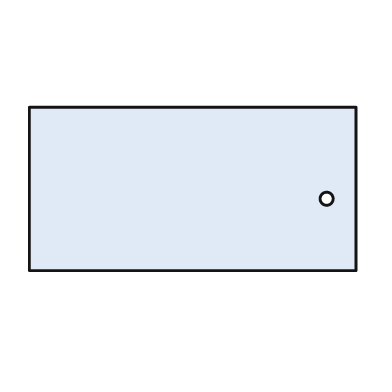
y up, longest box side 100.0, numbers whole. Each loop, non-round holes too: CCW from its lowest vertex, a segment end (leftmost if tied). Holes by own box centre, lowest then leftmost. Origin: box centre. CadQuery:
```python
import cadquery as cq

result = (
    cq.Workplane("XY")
    .moveTo(-50.0, -25.0)
    .lineTo(50.0, -25.0)
    .lineTo(50.0, 25.0)
    .lineTo(-50.0, 25.0)
    .close()
    .moveTo(41.0, -3.0)
    .circle(2.0)
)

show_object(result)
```